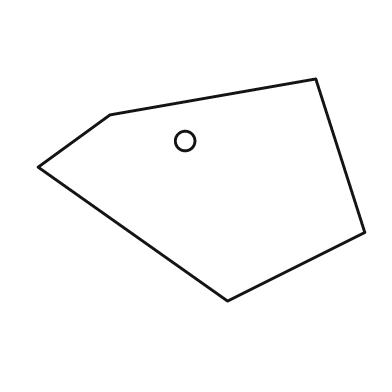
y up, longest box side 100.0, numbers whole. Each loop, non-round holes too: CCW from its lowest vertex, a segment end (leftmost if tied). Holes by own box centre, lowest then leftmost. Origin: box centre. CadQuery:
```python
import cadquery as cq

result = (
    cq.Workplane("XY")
    .moveTo(8.0, -34.0)
    .lineTo(50.0, -13.0)
    .lineTo(35.0, 34.0)
    .lineTo(-28.0, 23.0)
    .lineTo(-50.0, 7.0)
    .close()
    .moveTo(-5.0, 15.0)
    .circle(3.0)
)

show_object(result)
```